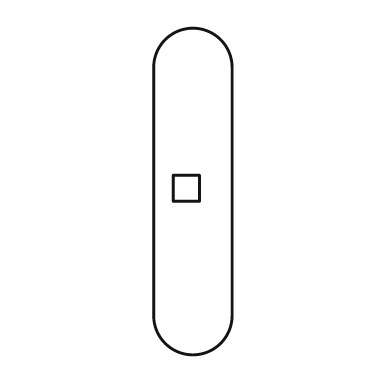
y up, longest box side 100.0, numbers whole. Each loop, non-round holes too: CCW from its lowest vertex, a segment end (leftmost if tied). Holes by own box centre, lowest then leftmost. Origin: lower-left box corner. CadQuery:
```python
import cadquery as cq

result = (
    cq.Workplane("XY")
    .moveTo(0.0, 12.0)
    .threePointArc((12.0, 0.0), (24.0, 12.0))
    .lineTo(24.0, 88.0)
    .threePointArc((12.0, 100.0), (0.0, 88.0))
    .close()
    .moveTo(6.0, 47.0)
    .lineTo(14.0, 47.0)
    .lineTo(14.0, 55.0)
    .lineTo(6.0, 55.0)
    .close()
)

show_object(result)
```